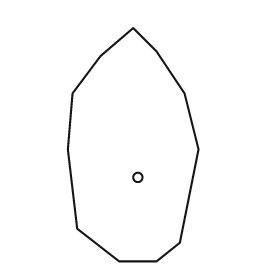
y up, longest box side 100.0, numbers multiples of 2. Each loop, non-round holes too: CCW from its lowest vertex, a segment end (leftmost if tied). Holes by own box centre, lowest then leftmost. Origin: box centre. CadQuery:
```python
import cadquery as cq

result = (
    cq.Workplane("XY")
    .moveTo(-6.0, -50.0)
    .lineTo(10.0, -50.0)
    .lineTo(20.0, -42.0)
    .lineTo(28.0, -2.0)
    .lineTo(22.0, 22.0)
    .lineTo(10.0, 40.0)
    .lineTo(0.0, 50.0)
    .lineTo(-14.0, 38.0)
    .lineTo(-26.0, 22.0)
    .lineTo(-28.0, -2.0)
    .lineTo(-24.0, -36.0)
    .close()
    .moveTo(2.0, -14.0)
    .circle(2.0)
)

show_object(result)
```